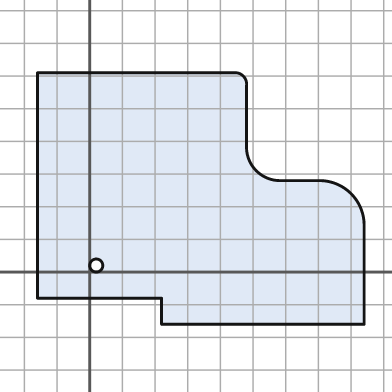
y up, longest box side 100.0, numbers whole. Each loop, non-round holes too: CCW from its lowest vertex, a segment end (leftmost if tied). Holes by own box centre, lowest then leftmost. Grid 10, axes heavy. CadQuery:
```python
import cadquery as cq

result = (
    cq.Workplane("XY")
    .moveTo(22.0, -16.0)
    .lineTo(84.0, -16.0)
    .lineTo(84.0, 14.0)
    .threePointArc((80.0, 24.0), (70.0, 28.0))
    .lineTo(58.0, 28.0)
    .threePointArc((51.0, 31.0), (48.0, 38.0))
    .lineTo(48.0, 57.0)
    .threePointArc((47.0, 60.0), (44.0, 61.0))
    .lineTo(-16.0, 61.0)
    .lineTo(-16.0, -8.0)
    .lineTo(22.0, -8.0)
    .close()
    .moveTo(2.0, 2.0)
    .circle(2.0)
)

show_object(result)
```